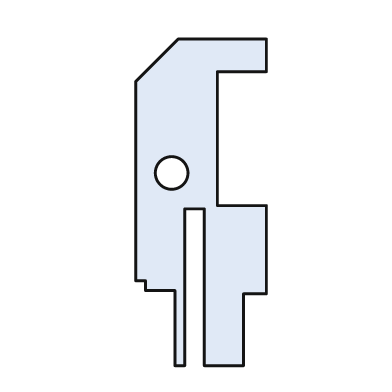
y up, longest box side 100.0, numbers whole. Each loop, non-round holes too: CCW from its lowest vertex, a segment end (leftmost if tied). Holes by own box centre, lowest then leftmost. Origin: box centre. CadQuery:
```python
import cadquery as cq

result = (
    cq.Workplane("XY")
    .moveTo(-8.0, -50.0)
    .lineTo(-5.0, -50.0)
    .lineTo(-5.0, -2.0)
    .lineTo(1.0, -2.0)
    .lineTo(1.0, -50.0)
    .lineTo(13.0, -50.0)
    .lineTo(13.0, -28.0)
    .lineTo(20.0, -28.0)
    .lineTo(20.0, -1.0)
    .lineTo(5.0, -1.0)
    .lineTo(5.0, 40.0)
    .lineTo(20.0, 40.0)
    .lineTo(20.0, 50.0)
    .lineTo(-7.0, 50.0)
    .lineTo(-20.0, 37.0)
    .lineTo(-20.0, -24.0)
    .lineTo(-17.0, -24.0)
    .lineTo(-17.0, -27.0)
    .lineTo(-8.0, -27.0)
    .close()
    .moveTo(-9.0, 9.0)
    .circle(5.0)
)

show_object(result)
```